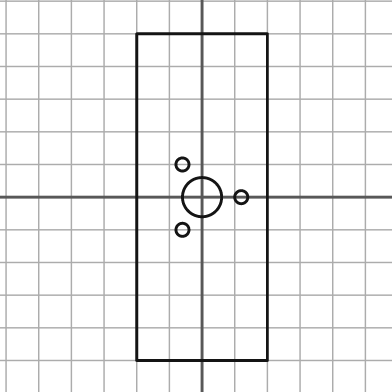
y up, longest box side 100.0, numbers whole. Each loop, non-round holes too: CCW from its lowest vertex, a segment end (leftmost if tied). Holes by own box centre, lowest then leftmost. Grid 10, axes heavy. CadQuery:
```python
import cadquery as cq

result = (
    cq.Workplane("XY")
    .moveTo(-20.0, -50.0)
    .lineTo(20.0, -50.0)
    .lineTo(20.0, 50.0)
    .lineTo(-20.0, 50.0)
    .close()
    .moveTo(-6.0, -10.0)
    .circle(2.0)
    .moveTo(0.0, 0.0)
    .circle(6.0)
    .moveTo(12.0, 0.0)
    .circle(2.0)
    .moveTo(-6.0, 10.0)
    .circle(2.0)
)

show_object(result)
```